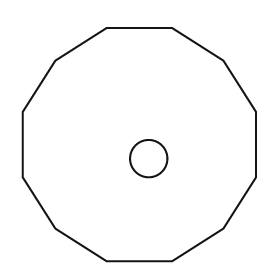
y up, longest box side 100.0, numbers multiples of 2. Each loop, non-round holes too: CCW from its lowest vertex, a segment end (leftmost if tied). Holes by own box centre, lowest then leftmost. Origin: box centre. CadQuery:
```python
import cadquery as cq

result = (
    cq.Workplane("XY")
    .moveTo(-14.0, -50.0)
    .lineTo(14.0, -50.0)
    .lineTo(36.0, -36.0)
    .lineTo(50.0, -14.0)
    .lineTo(50.0, 14.0)
    .lineTo(36.0, 36.0)
    .lineTo(14.0, 50.0)
    .lineTo(-14.0, 50.0)
    .lineTo(-36.0, 36.0)
    .lineTo(-50.0, 14.0)
    .lineTo(-50.0, -14.0)
    .lineTo(-36.0, -36.0)
    .close()
    .moveTo(4.0, -6.0)
    .circle(8.0)
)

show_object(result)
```